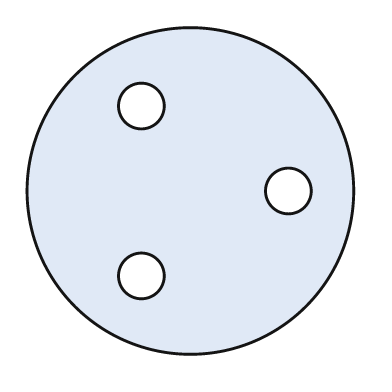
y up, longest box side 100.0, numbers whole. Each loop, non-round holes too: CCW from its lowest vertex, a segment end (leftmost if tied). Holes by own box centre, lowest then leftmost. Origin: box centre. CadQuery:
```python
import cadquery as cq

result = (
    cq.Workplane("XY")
    .moveTo(0.0, 0.0)
    .circle(50.0)
    .moveTo(-15.0, -26.0)
    .circle(7.0)
    .moveTo(30.0, 0.0)
    .circle(7.0)
    .moveTo(-15.0, 26.0)
    .circle(7.0)
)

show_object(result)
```